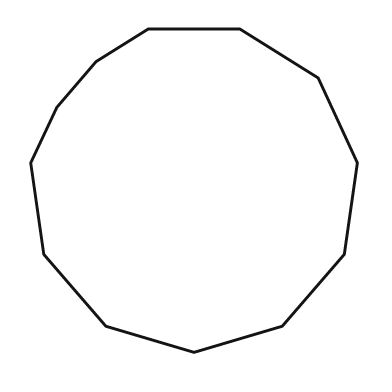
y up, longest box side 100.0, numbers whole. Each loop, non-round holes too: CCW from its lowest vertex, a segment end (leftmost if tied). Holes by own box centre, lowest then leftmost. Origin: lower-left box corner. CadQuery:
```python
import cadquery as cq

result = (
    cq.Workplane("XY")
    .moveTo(50.0, 0.0)
    .lineTo(77.0, 8.0)
    .lineTo(96.0, 30.0)
    .lineTo(100.0, 58.0)
    .lineTo(88.0, 84.0)
    .lineTo(64.0, 99.0)
    .lineTo(36.0, 99.0)
    .lineTo(20.0, 89.0)
    .lineTo(8.0, 75.0)
    .lineTo(0.0, 58.0)
    .lineTo(4.0, 30.0)
    .lineTo(23.0, 8.0)
    .close()
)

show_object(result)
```